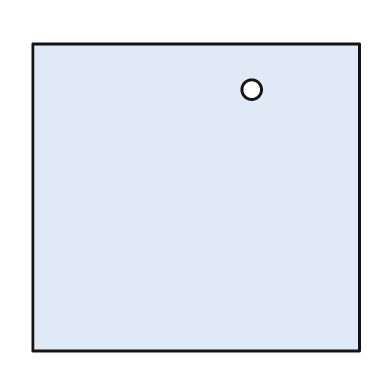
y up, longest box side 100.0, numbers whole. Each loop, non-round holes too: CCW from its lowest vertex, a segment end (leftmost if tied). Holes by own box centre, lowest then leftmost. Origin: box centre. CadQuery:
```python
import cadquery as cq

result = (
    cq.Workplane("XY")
    .moveTo(-50.0, -47.0)
    .lineTo(50.0, -47.0)
    .lineTo(50.0, 47.0)
    .lineTo(-50.0, 47.0)
    .close()
    .moveTo(17.0, 33.0)
    .circle(3.0)
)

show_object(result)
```